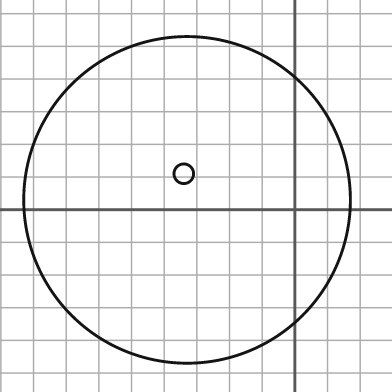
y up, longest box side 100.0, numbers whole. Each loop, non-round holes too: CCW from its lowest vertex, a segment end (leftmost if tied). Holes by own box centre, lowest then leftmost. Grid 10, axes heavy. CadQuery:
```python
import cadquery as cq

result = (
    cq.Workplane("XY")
    .moveTo(-33.0, 3.0)
    .circle(50.0)
    .moveTo(-34.0, 11.0)
    .circle(3.0)
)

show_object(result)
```